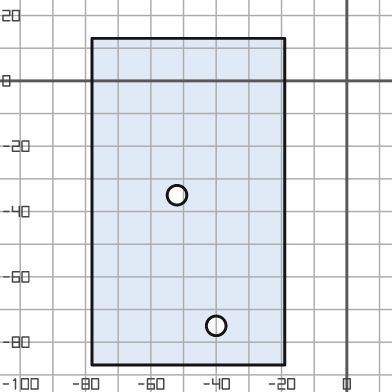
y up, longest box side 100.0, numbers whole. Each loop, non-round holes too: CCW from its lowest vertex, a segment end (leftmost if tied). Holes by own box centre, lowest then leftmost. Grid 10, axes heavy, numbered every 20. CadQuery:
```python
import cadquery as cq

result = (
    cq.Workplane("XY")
    .moveTo(-78.0, -87.0)
    .lineTo(-19.0, -87.0)
    .lineTo(-19.0, 13.0)
    .lineTo(-78.0, 13.0)
    .close()
    .moveTo(-40.0, -75.0)
    .circle(3.0)
    .moveTo(-52.0, -35.0)
    .circle(3.0)
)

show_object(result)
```